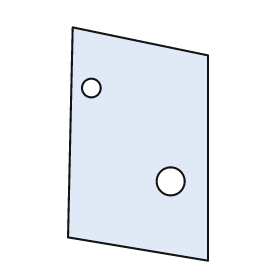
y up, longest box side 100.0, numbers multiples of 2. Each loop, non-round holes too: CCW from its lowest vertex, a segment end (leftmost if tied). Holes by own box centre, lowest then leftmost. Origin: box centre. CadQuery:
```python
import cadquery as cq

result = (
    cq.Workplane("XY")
    .moveTo(30.0, -50.0)
    .lineTo(30.0, 38.0)
    .lineTo(-28.0, 50.0)
    .lineTo(-30.0, -40.0)
    .close()
    .moveTo(14.0, -16.0)
    .circle(6.0)
    .moveTo(-20.0, 24.0)
    .circle(4.0)
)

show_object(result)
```